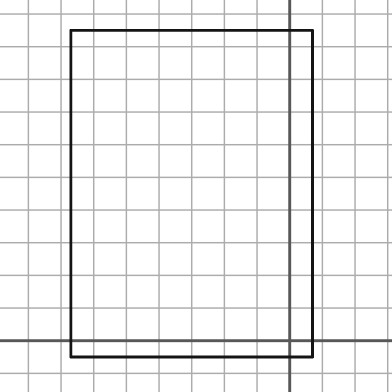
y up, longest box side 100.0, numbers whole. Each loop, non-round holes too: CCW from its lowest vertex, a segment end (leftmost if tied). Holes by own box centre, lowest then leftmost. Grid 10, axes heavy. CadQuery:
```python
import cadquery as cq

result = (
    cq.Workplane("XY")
    .moveTo(-67.0, -5.0)
    .lineTo(7.0, -5.0)
    .lineTo(7.0, 95.0)
    .lineTo(-67.0, 95.0)
    .close()
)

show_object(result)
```